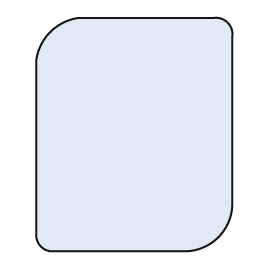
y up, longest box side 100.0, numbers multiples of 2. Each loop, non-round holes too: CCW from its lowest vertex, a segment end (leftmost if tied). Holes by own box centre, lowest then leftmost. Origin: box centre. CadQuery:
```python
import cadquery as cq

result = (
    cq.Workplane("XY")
    .moveTo(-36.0, -50.0)
    .lineTo(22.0, -50.0)
    .threePointArc((36.0, -44.0), (42.0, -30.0))
    .lineTo(42.0, 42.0)
    .threePointArc((40.0, 48.0), (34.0, 50.0))
    .lineTo(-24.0, 50.0)
    .threePointArc((-36.0, 44.0), (-42.0, 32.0))
    .lineTo(-42.0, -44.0)
    .threePointArc((-40.0, -48.0), (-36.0, -50.0))
    .close()
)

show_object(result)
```